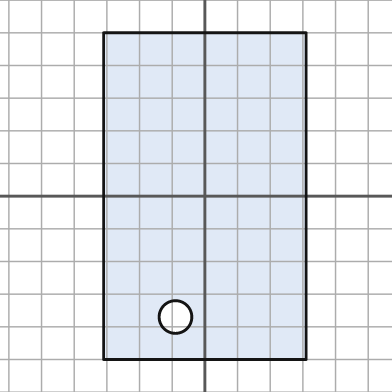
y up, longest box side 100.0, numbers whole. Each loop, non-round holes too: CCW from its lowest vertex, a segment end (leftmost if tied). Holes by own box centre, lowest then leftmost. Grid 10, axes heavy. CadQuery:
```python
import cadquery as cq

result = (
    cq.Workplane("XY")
    .moveTo(-31.0, -50.0)
    .lineTo(31.0, -50.0)
    .lineTo(31.0, 50.0)
    .lineTo(-31.0, 50.0)
    .close()
    .moveTo(-9.0, -37.0)
    .circle(5.0)
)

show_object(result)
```